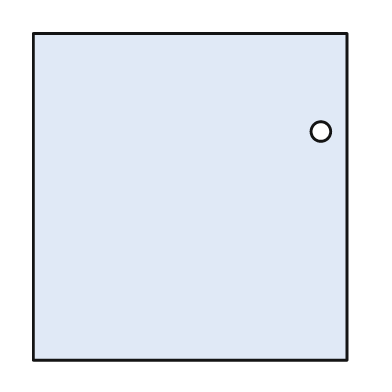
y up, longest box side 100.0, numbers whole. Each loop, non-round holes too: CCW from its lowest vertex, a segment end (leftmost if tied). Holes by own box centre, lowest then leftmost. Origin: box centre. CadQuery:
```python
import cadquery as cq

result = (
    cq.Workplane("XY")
    .moveTo(-48.0, -50.0)
    .lineTo(48.0, -50.0)
    .lineTo(48.0, 50.0)
    .lineTo(-48.0, 50.0)
    .close()
    .moveTo(40.0, 20.0)
    .circle(3.0)
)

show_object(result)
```